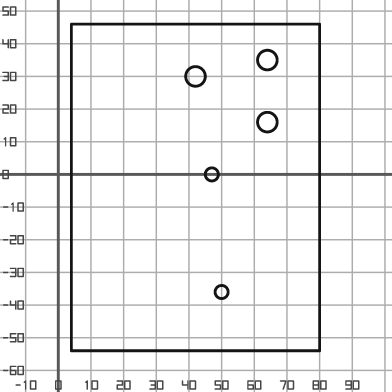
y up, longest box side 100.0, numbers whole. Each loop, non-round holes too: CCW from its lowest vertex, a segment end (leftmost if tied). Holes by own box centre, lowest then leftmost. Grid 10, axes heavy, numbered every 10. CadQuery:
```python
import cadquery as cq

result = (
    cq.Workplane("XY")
    .moveTo(4.0, -54.0)
    .lineTo(80.0, -54.0)
    .lineTo(80.0, 46.0)
    .lineTo(4.0, 46.0)
    .close()
    .moveTo(50.0, -36.0)
    .circle(2.0)
    .moveTo(47.0, 0.0)
    .circle(2.0)
    .moveTo(64.0, 16.0)
    .circle(3.0)
    .moveTo(42.0, 30.0)
    .circle(3.0)
    .moveTo(64.0, 35.0)
    .circle(3.0)
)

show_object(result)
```